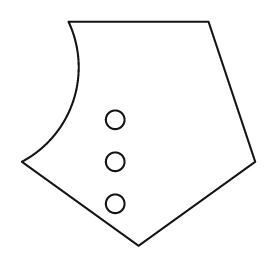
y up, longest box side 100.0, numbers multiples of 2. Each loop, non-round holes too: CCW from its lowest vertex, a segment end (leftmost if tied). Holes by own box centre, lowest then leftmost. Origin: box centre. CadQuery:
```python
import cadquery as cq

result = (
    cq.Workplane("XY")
    .moveTo(0.0, -48.0)
    .lineTo(50.0, -12.0)
    .lineTo(30.0, 48.0)
    .lineTo(-30.0, 48.0)
    .threePointArc((-28.0, 14.0), (-50.0, -12.0))
    .close()
    .moveTo(-10.0, -30.0)
    .circle(4.0)
    .moveTo(-10.0, -12.0)
    .circle(4.0)
    .moveTo(-10.0, 6.0)
    .circle(4.0)
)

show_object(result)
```